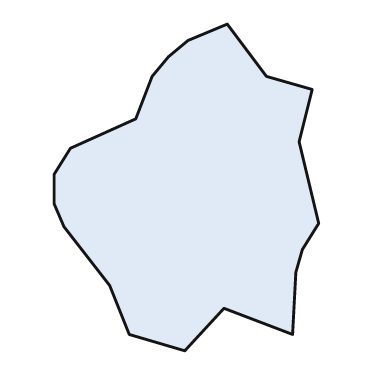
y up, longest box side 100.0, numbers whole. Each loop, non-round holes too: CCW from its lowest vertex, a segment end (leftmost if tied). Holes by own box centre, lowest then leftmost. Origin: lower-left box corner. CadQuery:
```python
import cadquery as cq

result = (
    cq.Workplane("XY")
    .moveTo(40.0, 0.0)
    .lineTo(52.0, 13.0)
    .lineTo(73.0, 5.0)
    .lineTo(74.0, 24.0)
    .lineTo(76.0, 31.0)
    .lineTo(81.0, 39.0)
    .lineTo(75.0, 64.0)
    .lineTo(79.0, 80.0)
    .lineTo(65.0, 84.0)
    .lineTo(53.0, 100.0)
    .lineTo(41.0, 95.0)
    .lineTo(35.0, 90.0)
    .lineTo(30.0, 84.0)
    .lineTo(25.0, 71.0)
    .lineTo(5.0, 62.0)
    .lineTo(0.0, 54.0)
    .lineTo(0.0, 45.0)
    .lineTo(3.0, 38.0)
    .lineTo(17.0, 20.0)
    .lineTo(23.0, 5.0)
    .close()
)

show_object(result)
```